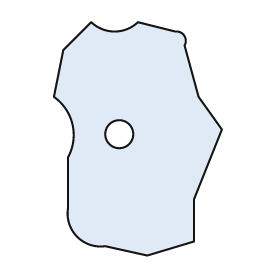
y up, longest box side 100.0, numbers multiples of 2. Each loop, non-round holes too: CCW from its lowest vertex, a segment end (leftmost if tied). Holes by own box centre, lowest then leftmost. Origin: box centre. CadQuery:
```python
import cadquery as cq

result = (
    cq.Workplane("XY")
    .moveTo(4.0, -50.0)
    .lineTo(24.0, -44.0)
    .lineTo(24.0, -26.0)
    .lineTo(36.0, 4.0)
    .lineTo(26.0, 18.0)
    .lineTo(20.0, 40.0)
    .threePointArc((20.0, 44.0), (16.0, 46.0))
    .lineTo(0.0, 50.0)
    .threePointArc((-10.0, 46.0), (-20.0, 50.0))
    .lineTo(-32.0, 38.0)
    .lineTo(-36.0, 18.0)
    .threePointArc((-28.0, 6.0), (-30.0, -8.0))
    .lineTo(-30.0, -30.0)
    .threePointArc((-26.0, -42.0), (-14.0, -46.0))
    .close()
    .moveTo(-8.0, 2.0)
    .circle(6.0)
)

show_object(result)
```